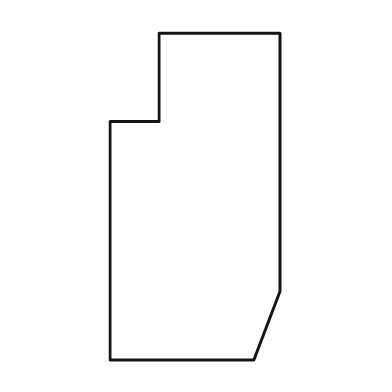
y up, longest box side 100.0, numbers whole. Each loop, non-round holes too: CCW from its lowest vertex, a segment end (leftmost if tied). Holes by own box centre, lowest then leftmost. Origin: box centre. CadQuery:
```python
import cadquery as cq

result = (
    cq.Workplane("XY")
    .moveTo(-26.0, -50.0)
    .lineTo(18.0, -50.0)
    .lineTo(26.0, -29.0)
    .lineTo(26.0, 50.0)
    .lineTo(-11.0, 50.0)
    .lineTo(-11.0, 23.0)
    .lineTo(-26.0, 23.0)
    .close()
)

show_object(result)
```